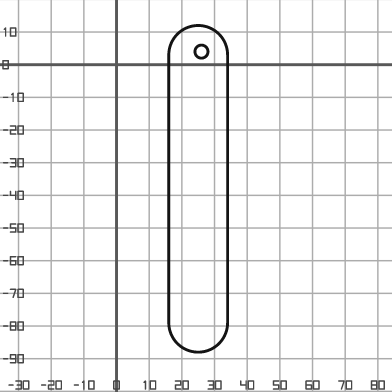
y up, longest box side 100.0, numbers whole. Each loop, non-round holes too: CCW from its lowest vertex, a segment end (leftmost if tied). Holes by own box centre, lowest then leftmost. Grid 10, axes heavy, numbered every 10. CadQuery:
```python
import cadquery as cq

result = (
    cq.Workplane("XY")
    .moveTo(16.0, -79.0)
    .threePointArc((25.0, -88.0), (34.0, -79.0))
    .lineTo(34.0, 3.0)
    .threePointArc((25.0, 12.0), (16.0, 3.0))
    .close()
    .moveTo(26.0, 4.0)
    .circle(2.0)
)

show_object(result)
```